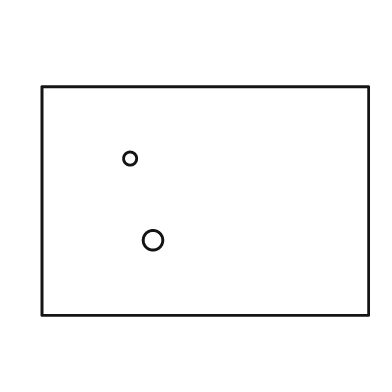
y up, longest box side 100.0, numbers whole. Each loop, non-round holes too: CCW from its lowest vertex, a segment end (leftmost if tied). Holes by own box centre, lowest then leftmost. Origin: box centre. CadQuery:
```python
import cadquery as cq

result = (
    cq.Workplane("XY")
    .moveTo(-50.0, -35.0)
    .lineTo(50.0, -35.0)
    .lineTo(50.0, 35.0)
    .lineTo(-50.0, 35.0)
    .close()
    .moveTo(-16.0, -12.0)
    .circle(3.0)
    .moveTo(-23.0, 13.0)
    .circle(2.0)
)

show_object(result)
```